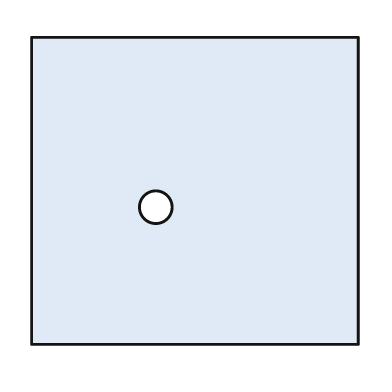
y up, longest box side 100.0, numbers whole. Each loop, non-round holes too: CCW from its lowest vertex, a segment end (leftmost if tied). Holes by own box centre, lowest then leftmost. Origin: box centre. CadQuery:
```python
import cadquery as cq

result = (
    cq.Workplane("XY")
    .moveTo(-50.0, -47.0)
    .lineTo(50.0, -47.0)
    .lineTo(50.0, 47.0)
    .lineTo(-50.0, 47.0)
    .close()
    .moveTo(-12.0, -5.0)
    .circle(5.0)
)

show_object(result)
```